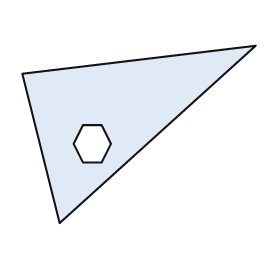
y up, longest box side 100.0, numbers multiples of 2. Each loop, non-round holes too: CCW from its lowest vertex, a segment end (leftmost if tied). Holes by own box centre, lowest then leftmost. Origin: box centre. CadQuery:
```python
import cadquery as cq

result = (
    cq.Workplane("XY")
    .moveTo(-34.0, -38.0)
    .lineTo(50.0, 38.0)
    .lineTo(-50.0, 26.0)
    .close()
    .moveTo(-24.0, -12.0)
    .lineTo(-16.0, -12.0)
    .lineTo(-12.0, -4.0)
    .lineTo(-16.0, 4.0)
    .lineTo(-24.0, 4.0)
    .lineTo(-28.0, -4.0)
    .close()
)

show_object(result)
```